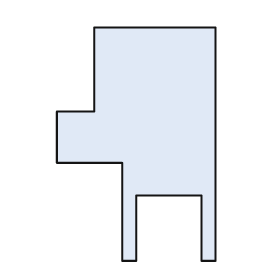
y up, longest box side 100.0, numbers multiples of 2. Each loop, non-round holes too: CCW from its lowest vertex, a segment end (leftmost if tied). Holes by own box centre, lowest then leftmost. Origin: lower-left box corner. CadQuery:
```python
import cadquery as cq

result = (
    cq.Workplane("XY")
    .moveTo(28.0, 0.0)
    .lineTo(34.0, 0.0)
    .lineTo(34.0, 28.0)
    .lineTo(62.0, 28.0)
    .lineTo(62.0, 0.0)
    .lineTo(68.0, 0.0)
    .lineTo(68.0, 100.0)
    .lineTo(16.0, 100.0)
    .lineTo(16.0, 64.0)
    .lineTo(0.0, 64.0)
    .lineTo(0.0, 42.0)
    .lineTo(28.0, 42.0)
    .close()
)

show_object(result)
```